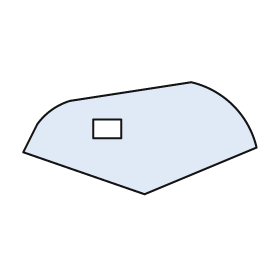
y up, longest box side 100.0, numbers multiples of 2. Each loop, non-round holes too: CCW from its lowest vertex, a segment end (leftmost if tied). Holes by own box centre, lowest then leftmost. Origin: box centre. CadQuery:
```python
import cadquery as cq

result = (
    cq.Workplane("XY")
    .moveTo(2.0, -24.0)
    .lineTo(50.0, -4.0)
    .threePointArc((40.0, 14.0), (22.0, 24.0))
    .lineTo(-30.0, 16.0)
    .threePointArc((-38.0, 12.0), (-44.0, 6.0))
    .lineTo(-50.0, -6.0)
    .close()
    .moveTo(-20.0, 0.0)
    .lineTo(-8.0, 0.0)
    .lineTo(-8.0, 8.0)
    .lineTo(-20.0, 8.0)
    .close()
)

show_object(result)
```